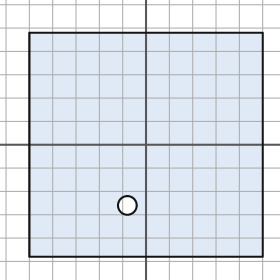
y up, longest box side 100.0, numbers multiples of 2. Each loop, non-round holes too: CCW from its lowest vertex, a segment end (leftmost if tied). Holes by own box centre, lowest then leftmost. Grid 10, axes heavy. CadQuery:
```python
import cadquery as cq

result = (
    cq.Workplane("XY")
    .moveTo(-50.0, -48.0)
    .lineTo(50.0, -48.0)
    .lineTo(50.0, 48.0)
    .lineTo(-50.0, 48.0)
    .close()
    .moveTo(-8.0, -26.0)
    .circle(4.0)
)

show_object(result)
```